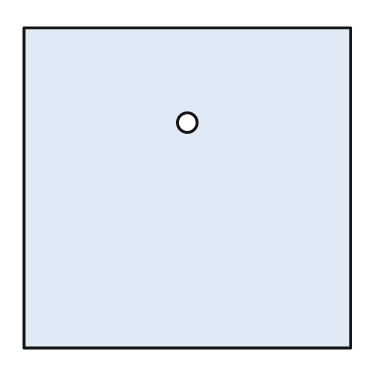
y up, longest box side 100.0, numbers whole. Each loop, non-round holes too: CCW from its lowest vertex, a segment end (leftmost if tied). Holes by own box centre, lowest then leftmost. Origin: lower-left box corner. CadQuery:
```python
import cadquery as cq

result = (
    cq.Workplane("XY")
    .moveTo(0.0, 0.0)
    .lineTo(100.0, 0.0)
    .lineTo(100.0, 98.0)
    .lineTo(0.0, 98.0)
    .close()
    .moveTo(50.0, 69.0)
    .circle(3.0)
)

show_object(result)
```